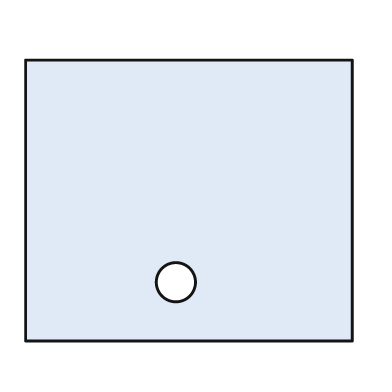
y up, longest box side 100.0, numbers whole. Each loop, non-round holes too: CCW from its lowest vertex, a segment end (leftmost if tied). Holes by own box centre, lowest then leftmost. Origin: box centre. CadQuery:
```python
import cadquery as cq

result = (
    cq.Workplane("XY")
    .moveTo(-50.0, -43.0)
    .lineTo(50.0, -43.0)
    .lineTo(50.0, 43.0)
    .lineTo(-50.0, 43.0)
    .close()
    .moveTo(-4.0, -25.0)
    .circle(6.0)
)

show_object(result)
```